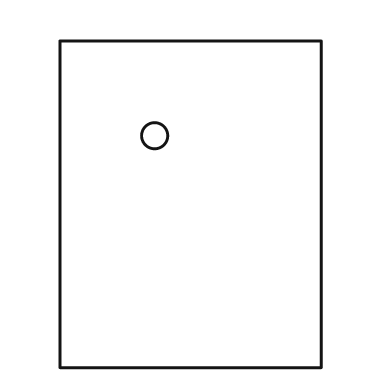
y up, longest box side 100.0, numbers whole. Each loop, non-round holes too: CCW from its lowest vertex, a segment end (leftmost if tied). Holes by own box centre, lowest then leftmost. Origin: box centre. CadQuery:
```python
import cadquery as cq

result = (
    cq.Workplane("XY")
    .moveTo(-40.0, -50.0)
    .lineTo(40.0, -50.0)
    .lineTo(40.0, 50.0)
    .lineTo(-40.0, 50.0)
    .close()
    .moveTo(-11.0, 21.0)
    .circle(4.0)
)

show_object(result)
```